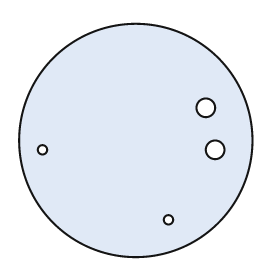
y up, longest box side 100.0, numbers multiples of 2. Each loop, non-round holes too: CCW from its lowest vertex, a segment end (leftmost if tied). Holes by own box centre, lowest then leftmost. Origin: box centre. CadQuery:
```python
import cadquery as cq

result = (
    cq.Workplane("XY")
    .moveTo(0.0, 0.0)
    .circle(50.0)
    .moveTo(14.0, -34.0)
    .circle(2.0)
    .moveTo(-40.0, -4.0)
    .circle(2.0)
    .moveTo(34.0, -4.0)
    .circle(4.0)
    .moveTo(30.0, 14.0)
    .circle(4.0)
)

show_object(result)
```